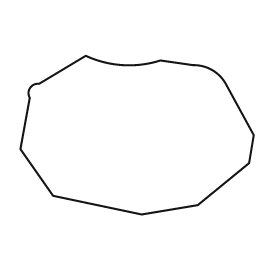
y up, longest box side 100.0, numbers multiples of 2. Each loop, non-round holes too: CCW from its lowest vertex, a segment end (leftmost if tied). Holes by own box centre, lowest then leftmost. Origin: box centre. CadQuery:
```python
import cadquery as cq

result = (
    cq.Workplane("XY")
    .moveTo(2.0, -34.0)
    .lineTo(26.0, -30.0)
    .lineTo(48.0, -12.0)
    .lineTo(50.0, 0.0)
    .lineTo(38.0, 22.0)
    .threePointArc((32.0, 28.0), (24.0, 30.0))
    .lineTo(10.0, 32.0)
    .threePointArc((-6.0, 30.0), (-22.0, 34.0))
    .lineTo(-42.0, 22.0)
    .threePointArc((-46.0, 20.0), (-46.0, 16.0))
    .lineTo(-50.0, -6.0)
    .lineTo(-36.0, -26.0)
    .close()
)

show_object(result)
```